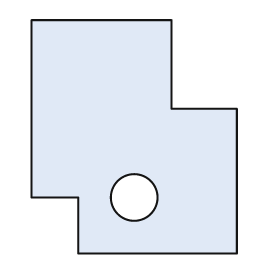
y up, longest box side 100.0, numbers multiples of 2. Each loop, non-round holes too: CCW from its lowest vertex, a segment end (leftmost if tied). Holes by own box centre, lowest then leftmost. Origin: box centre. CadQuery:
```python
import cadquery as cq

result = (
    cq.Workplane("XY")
    .moveTo(-24.0, -50.0)
    .lineTo(44.0, -50.0)
    .lineTo(44.0, 12.0)
    .lineTo(16.0, 12.0)
    .lineTo(16.0, 50.0)
    .lineTo(-44.0, 50.0)
    .lineTo(-44.0, -26.0)
    .lineTo(-24.0, -26.0)
    .close()
    .moveTo(0.0, -26.0)
    .circle(10.0)
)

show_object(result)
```